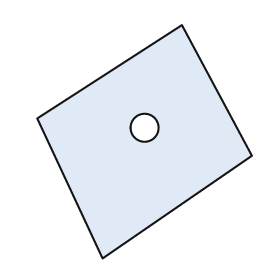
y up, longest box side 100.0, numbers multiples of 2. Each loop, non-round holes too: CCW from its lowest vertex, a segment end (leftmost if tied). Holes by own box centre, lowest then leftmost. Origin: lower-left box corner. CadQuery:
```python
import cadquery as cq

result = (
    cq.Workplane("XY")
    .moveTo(28.0, 0.0)
    .lineTo(92.0, 44.0)
    .lineTo(62.0, 100.0)
    .lineTo(0.0, 60.0)
    .close()
    .moveTo(46.0, 56.0)
    .circle(6.0)
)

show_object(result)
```